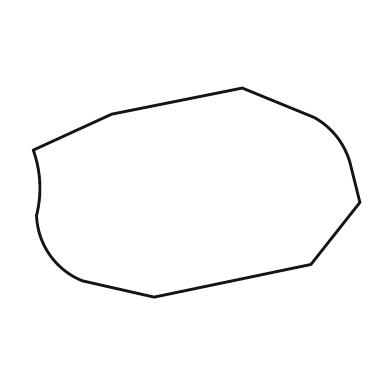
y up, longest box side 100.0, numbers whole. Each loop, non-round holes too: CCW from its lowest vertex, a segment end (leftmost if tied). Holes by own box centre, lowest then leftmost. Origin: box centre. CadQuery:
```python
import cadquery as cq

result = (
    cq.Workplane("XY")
    .moveTo(-13.0, -32.0)
    .lineTo(35.0, -22.0)
    .lineTo(50.0, -3.0)
    .lineTo(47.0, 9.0)
    .threePointArc((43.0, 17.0), (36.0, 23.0))
    .lineTo(14.0, 32.0)
    .lineTo(-26.0, 24.0)
    .lineTo(-50.0, 13.0)
    .threePointArc((-48.0, 3.0), (-49.0, -7.0))
    .threePointArc((-45.0, -19.0), (-35.0, -27.0))
    .close()
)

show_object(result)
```